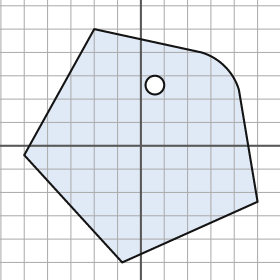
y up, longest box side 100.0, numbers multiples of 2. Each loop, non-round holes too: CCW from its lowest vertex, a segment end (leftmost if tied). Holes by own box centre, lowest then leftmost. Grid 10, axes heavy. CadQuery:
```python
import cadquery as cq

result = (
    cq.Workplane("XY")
    .moveTo(-8.0, -50.0)
    .lineTo(50.0, -24.0)
    .lineTo(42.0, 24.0)
    .threePointArc((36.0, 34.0), (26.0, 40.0))
    .lineTo(-20.0, 50.0)
    .lineTo(-50.0, -4.0)
    .close()
    .moveTo(6.0, 26.0)
    .circle(4.0)
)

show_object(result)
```